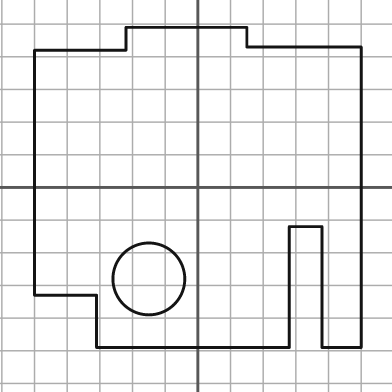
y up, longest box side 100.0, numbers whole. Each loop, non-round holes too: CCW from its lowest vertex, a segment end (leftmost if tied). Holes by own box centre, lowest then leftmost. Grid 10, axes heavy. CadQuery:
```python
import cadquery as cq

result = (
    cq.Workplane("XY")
    .moveTo(-31.0, -49.0)
    .lineTo(28.0, -49.0)
    .lineTo(28.0, -12.0)
    .lineTo(38.0, -12.0)
    .lineTo(38.0, -49.0)
    .lineTo(50.0, -49.0)
    .lineTo(50.0, 43.0)
    .lineTo(15.0, 43.0)
    .lineTo(15.0, 49.0)
    .lineTo(-22.0, 49.0)
    .lineTo(-22.0, 42.0)
    .lineTo(-50.0, 42.0)
    .lineTo(-50.0, -33.0)
    .lineTo(-31.0, -33.0)
    .close()
    .moveTo(-15.0, -28.0)
    .circle(11.0)
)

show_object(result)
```